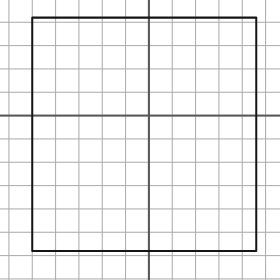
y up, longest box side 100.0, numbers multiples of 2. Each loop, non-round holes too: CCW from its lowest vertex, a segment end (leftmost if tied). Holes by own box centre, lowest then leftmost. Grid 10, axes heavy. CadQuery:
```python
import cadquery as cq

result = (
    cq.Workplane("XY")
    .moveTo(-50.0, -58.0)
    .lineTo(46.0, -58.0)
    .lineTo(46.0, 42.0)
    .lineTo(-50.0, 42.0)
    .close()
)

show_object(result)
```